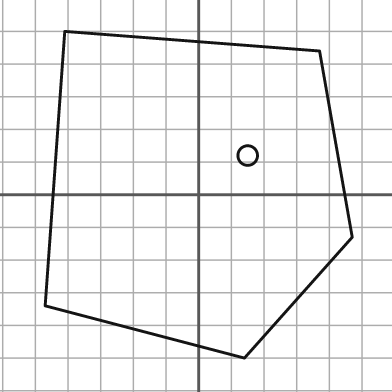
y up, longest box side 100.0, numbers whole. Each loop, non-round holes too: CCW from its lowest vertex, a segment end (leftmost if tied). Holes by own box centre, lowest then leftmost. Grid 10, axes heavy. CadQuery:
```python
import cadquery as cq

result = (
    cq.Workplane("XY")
    .moveTo(14.0, -50.0)
    .lineTo(47.0, -13.0)
    .lineTo(37.0, 44.0)
    .lineTo(-41.0, 50.0)
    .lineTo(-47.0, -34.0)
    .close()
    .moveTo(15.0, 12.0)
    .circle(3.0)
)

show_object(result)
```